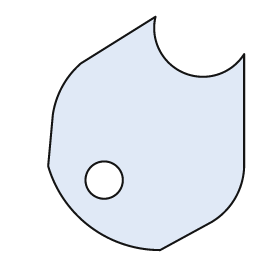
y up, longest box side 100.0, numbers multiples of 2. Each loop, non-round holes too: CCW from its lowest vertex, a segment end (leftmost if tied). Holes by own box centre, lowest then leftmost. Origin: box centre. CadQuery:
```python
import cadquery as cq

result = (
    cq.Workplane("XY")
    .moveTo(6.0, -50.0)
    .lineTo(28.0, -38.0)
    .threePointArc((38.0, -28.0), (42.0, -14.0))
    .lineTo(42.0, 34.0)
    .threePointArc((16.0, 26.0), (4.0, 50.0))
    .lineTo(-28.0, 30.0)
    .threePointArc((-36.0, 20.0), (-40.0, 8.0))
    .lineTo(-42.0, -14.0)
    .threePointArc((-24.0, -40.0), (6.0, -50.0))
    .close()
    .moveTo(-18.0, -20.0)
    .circle(8.0)
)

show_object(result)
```